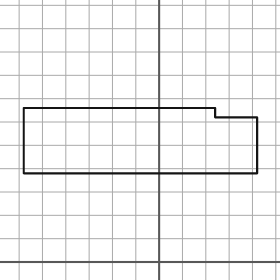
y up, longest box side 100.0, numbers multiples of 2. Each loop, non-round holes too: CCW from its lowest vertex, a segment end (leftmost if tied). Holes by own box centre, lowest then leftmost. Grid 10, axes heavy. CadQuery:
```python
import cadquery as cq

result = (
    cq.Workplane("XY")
    .moveTo(-58.0, 38.0)
    .lineTo(42.0, 38.0)
    .lineTo(42.0, 62.0)
    .lineTo(24.0, 62.0)
    .lineTo(24.0, 66.0)
    .lineTo(-58.0, 66.0)
    .close()
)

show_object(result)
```